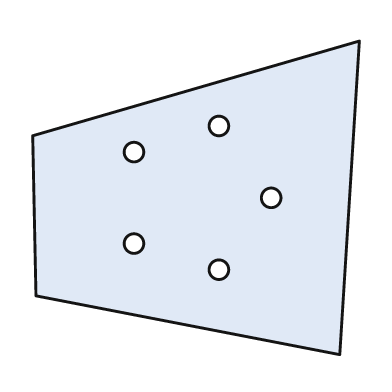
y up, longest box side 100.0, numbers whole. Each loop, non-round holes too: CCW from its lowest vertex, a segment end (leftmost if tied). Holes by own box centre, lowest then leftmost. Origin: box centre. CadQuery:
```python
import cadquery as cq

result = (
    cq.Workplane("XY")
    .moveTo(44.0, -48.0)
    .lineTo(50.0, 48.0)
    .lineTo(-50.0, 19.0)
    .lineTo(-49.0, -30.0)
    .close()
    .moveTo(7.0, -22.0)
    .circle(3.0)
    .moveTo(-19.0, -14.0)
    .circle(3.0)
    .moveTo(23.0, 0.0)
    .circle(3.0)
    .moveTo(-19.0, 14.0)
    .circle(3.0)
    .moveTo(7.0, 22.0)
    .circle(3.0)
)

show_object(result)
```